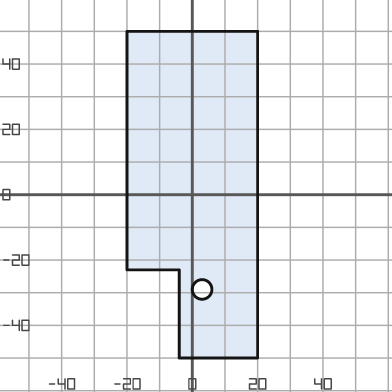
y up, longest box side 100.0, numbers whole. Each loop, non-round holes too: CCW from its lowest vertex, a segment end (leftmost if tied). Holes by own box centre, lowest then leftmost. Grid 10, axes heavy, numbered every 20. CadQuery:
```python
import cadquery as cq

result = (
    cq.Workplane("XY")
    .moveTo(-4.0, -50.0)
    .lineTo(20.0, -50.0)
    .lineTo(20.0, 50.0)
    .lineTo(-20.0, 50.0)
    .lineTo(-20.0, -23.0)
    .lineTo(-4.0, -23.0)
    .close()
    .moveTo(3.0, -29.0)
    .circle(3.0)
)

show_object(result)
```